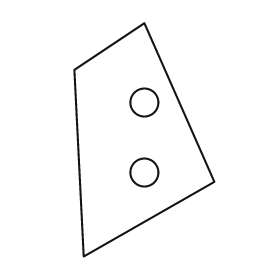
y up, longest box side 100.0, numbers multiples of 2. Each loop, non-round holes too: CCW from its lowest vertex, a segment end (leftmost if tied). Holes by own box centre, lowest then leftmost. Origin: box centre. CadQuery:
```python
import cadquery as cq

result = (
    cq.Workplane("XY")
    .moveTo(-26.0, -50.0)
    .lineTo(30.0, -18.0)
    .lineTo(0.0, 50.0)
    .lineTo(-30.0, 30.0)
    .close()
    .moveTo(0.0, -14.0)
    .circle(6.0)
    .moveTo(0.0, 16.0)
    .circle(6.0)
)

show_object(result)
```